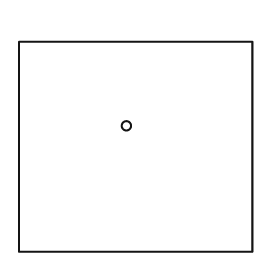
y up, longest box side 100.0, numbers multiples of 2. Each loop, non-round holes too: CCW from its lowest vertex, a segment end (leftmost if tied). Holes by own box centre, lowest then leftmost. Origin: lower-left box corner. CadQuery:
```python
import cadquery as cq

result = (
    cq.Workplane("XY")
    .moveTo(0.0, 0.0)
    .lineTo(100.0, 0.0)
    .lineTo(100.0, 90.0)
    .lineTo(0.0, 90.0)
    .close()
    .moveTo(46.0, 54.0)
    .circle(2.0)
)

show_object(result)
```